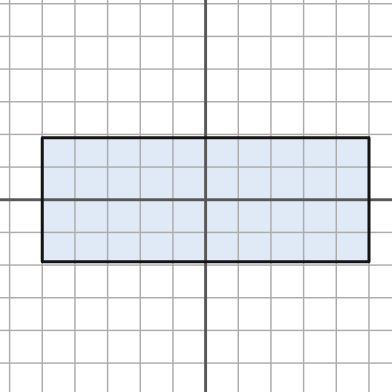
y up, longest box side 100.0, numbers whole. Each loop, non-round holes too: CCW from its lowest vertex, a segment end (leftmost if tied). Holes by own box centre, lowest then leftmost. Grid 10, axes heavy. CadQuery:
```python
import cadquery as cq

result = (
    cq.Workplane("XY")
    .moveTo(-50.0, -19.0)
    .lineTo(50.0, -19.0)
    .lineTo(50.0, 19.0)
    .lineTo(-50.0, 19.0)
    .close()
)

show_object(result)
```